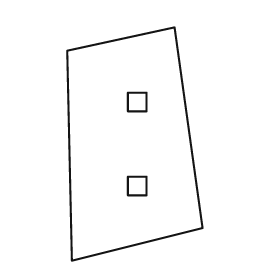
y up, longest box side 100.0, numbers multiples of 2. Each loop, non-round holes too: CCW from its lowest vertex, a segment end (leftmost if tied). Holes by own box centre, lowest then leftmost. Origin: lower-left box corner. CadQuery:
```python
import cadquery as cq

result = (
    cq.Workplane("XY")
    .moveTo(2.0, 0.0)
    .lineTo(58.0, 14.0)
    .lineTo(46.0, 100.0)
    .lineTo(0.0, 90.0)
    .close()
    .moveTo(26.0, 28.0)
    .lineTo(34.0, 28.0)
    .lineTo(34.0, 36.0)
    .lineTo(26.0, 36.0)
    .close()
    .moveTo(26.0, 64.0)
    .lineTo(34.0, 64.0)
    .lineTo(34.0, 72.0)
    .lineTo(26.0, 72.0)
    .close()
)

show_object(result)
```